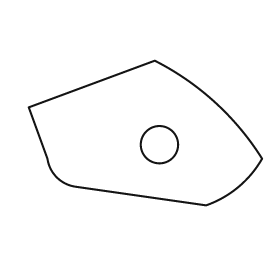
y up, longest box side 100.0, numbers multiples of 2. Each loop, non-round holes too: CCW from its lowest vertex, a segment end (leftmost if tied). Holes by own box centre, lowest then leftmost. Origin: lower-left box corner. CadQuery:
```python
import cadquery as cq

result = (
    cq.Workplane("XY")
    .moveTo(76.0, 0.0)
    .threePointArc((90.0, 8.0), (100.0, 20.0))
    .threePointArc((80.0, 44.0), (54.0, 62.0))
    .lineTo(0.0, 42.0)
    .lineTo(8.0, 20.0)
    .threePointArc((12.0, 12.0), (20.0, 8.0))
    .close()
    .moveTo(56.0, 26.0)
    .circle(8.0)
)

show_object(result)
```